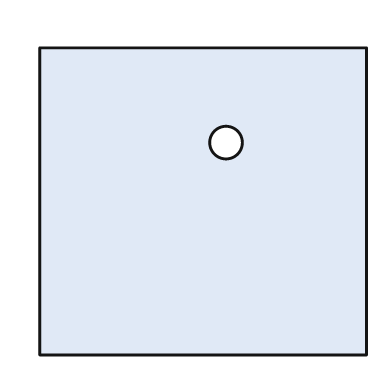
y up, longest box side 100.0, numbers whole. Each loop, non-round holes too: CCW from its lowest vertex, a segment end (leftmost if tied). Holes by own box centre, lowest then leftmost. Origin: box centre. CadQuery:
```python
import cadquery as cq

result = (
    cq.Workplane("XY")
    .moveTo(-50.0, -47.0)
    .lineTo(50.0, -47.0)
    .lineTo(50.0, 47.0)
    .lineTo(-50.0, 47.0)
    .close()
    .moveTo(7.0, 18.0)
    .circle(5.0)
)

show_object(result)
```